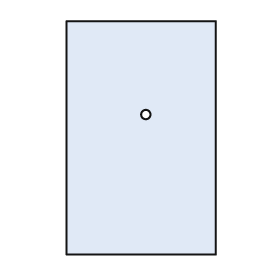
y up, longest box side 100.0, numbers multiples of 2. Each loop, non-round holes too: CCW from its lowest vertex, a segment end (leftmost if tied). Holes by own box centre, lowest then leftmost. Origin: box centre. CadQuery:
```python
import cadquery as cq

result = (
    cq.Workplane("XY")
    .moveTo(-32.0, -50.0)
    .lineTo(32.0, -50.0)
    .lineTo(32.0, 50.0)
    .lineTo(-32.0, 50.0)
    .close()
    .moveTo(2.0, 10.0)
    .circle(2.0)
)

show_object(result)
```